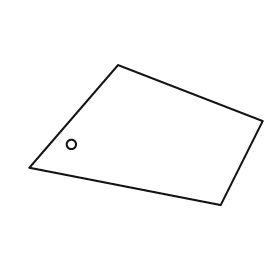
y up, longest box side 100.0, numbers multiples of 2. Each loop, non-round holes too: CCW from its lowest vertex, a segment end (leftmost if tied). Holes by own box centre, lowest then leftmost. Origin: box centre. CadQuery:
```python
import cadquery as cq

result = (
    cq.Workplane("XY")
    .moveTo(32.0, -30.0)
    .lineTo(50.0, 6.0)
    .lineTo(-12.0, 30.0)
    .lineTo(-50.0, -14.0)
    .close()
    .moveTo(-32.0, -4.0)
    .circle(2.0)
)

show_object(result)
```